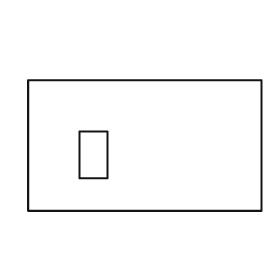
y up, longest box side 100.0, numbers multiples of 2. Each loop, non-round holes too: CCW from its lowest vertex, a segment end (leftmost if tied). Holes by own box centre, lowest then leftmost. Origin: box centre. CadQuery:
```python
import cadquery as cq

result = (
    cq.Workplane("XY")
    .moveTo(-50.0, -28.0)
    .lineTo(50.0, -28.0)
    .lineTo(50.0, 28.0)
    .lineTo(-50.0, 28.0)
    .close()
    .moveTo(-28.0, -14.0)
    .lineTo(-16.0, -14.0)
    .lineTo(-16.0, 6.0)
    .lineTo(-28.0, 6.0)
    .close()
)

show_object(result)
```